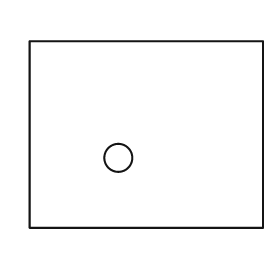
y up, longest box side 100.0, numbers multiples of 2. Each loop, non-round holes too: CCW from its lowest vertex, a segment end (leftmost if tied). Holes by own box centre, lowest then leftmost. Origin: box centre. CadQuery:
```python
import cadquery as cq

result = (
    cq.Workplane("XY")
    .moveTo(-50.0, -40.0)
    .lineTo(50.0, -40.0)
    .lineTo(50.0, 40.0)
    .lineTo(-50.0, 40.0)
    .close()
    .moveTo(-12.0, -10.0)
    .circle(6.0)
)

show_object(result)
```